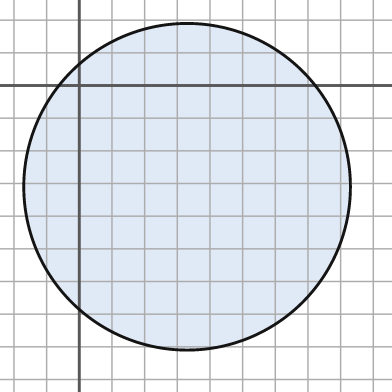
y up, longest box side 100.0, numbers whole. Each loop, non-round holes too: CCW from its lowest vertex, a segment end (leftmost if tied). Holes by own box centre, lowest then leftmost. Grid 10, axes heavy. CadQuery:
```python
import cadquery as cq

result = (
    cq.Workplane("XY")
    .moveTo(33.0, -31.0)
    .circle(50.0)
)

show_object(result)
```